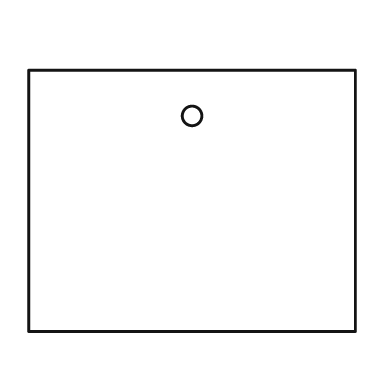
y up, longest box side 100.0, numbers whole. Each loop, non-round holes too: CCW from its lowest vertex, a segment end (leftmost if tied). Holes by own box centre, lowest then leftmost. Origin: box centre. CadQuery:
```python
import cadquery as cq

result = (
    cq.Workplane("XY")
    .moveTo(-50.0, -40.0)
    .lineTo(50.0, -40.0)
    .lineTo(50.0, 40.0)
    .lineTo(-50.0, 40.0)
    .close()
    .moveTo(0.0, 26.0)
    .circle(3.0)
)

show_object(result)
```